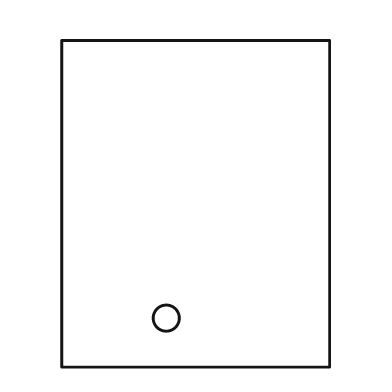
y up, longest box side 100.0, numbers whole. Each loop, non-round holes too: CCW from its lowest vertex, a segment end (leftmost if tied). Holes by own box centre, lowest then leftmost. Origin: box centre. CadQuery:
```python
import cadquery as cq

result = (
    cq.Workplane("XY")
    .moveTo(-41.0, -50.0)
    .lineTo(41.0, -50.0)
    .lineTo(41.0, 50.0)
    .lineTo(-41.0, 50.0)
    .close()
    .moveTo(-9.0, -35.0)
    .circle(4.0)
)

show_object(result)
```